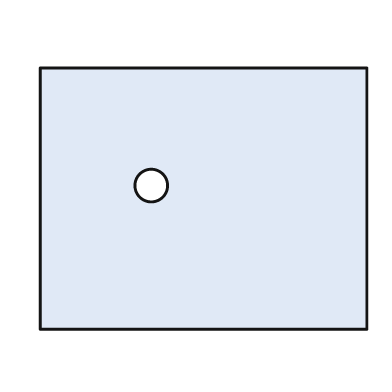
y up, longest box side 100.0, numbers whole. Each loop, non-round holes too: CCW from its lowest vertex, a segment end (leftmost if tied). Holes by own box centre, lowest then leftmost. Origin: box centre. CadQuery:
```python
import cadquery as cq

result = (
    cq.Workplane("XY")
    .moveTo(-50.0, -40.0)
    .lineTo(50.0, -40.0)
    .lineTo(50.0, 40.0)
    .lineTo(-50.0, 40.0)
    .close()
    .moveTo(-16.0, 4.0)
    .circle(5.0)
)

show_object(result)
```